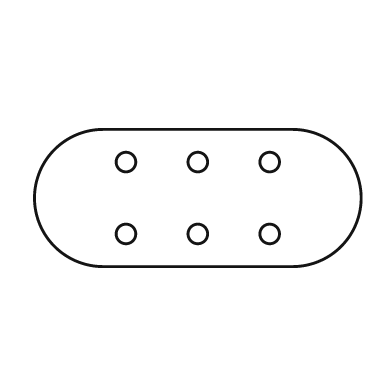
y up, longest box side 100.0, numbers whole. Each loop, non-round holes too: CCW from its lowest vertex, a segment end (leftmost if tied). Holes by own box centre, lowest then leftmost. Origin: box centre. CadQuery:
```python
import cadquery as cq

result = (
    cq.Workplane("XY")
    .moveTo(-29.0, -21.0)
    .lineTo(29.0, -21.0)
    .threePointArc((50.0, 0.0), (29.0, 21.0))
    .lineTo(-29.0, 21.0)
    .threePointArc((-50.0, 0.0), (-29.0, -21.0))
    .close()
    .moveTo(-22.0, -11.0)
    .circle(3.0)
    .moveTo(0.0, -11.0)
    .circle(3.0)
    .moveTo(22.0, -11.0)
    .circle(3.0)
    .moveTo(-22.0, 11.0)
    .circle(3.0)
    .moveTo(0.0, 11.0)
    .circle(3.0)
    .moveTo(22.0, 11.0)
    .circle(3.0)
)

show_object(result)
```